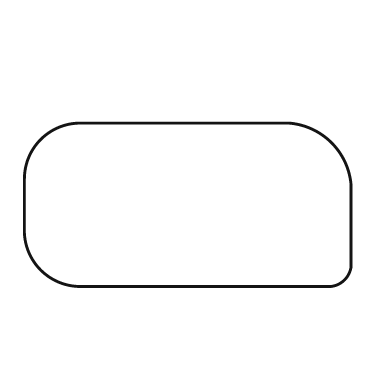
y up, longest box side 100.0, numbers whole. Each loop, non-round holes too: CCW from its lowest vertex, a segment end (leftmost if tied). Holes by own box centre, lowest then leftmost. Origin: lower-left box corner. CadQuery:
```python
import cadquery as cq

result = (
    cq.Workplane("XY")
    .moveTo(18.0, 0.0)
    .lineTo(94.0, 0.0)
    .threePointArc((98.0, 2.0), (100.0, 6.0))
    .lineTo(100.0, 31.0)
    .threePointArc((94.0, 44.0), (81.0, 50.0))
    .lineTo(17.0, 50.0)
    .threePointArc((5.0, 45.0), (0.0, 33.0))
    .lineTo(0.0, 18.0)
    .threePointArc((5.0, 5.0), (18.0, 0.0))
    .close()
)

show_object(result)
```